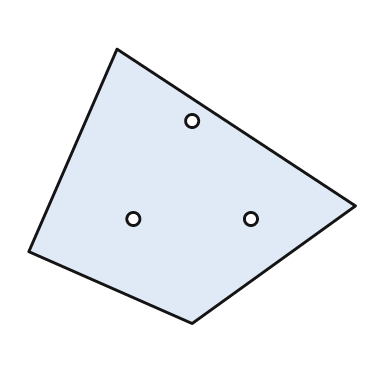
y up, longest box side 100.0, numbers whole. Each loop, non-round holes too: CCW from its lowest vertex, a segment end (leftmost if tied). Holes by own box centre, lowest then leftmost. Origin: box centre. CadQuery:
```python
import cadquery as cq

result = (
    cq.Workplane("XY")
    .moveTo(0.0, -42.0)
    .lineTo(50.0, -6.0)
    .lineTo(-23.0, 42.0)
    .lineTo(-50.0, -20.0)
    .close()
    .moveTo(-18.0, -10.0)
    .circle(2.0)
    .moveTo(18.0, -10.0)
    .circle(2.0)
    .moveTo(0.0, 20.0)
    .circle(2.0)
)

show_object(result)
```